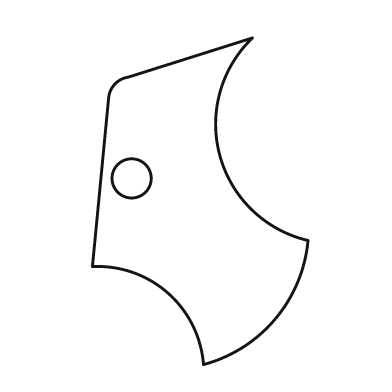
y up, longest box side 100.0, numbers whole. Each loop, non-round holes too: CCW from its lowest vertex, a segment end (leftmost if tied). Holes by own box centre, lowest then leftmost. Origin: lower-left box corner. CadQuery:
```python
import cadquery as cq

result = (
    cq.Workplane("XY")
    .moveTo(34.0, 0.0)
    .threePointArc((56.0, 14.0), (66.0, 38.0))
    .threePointArc((39.0, 64.0), (49.0, 100.0))
    .lineTo(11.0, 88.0)
    .threePointArc((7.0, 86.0), (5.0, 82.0))
    .lineTo(0.0, 30.0)
    .threePointArc((23.0, 22.0), (34.0, 0.0))
    .close()
    .moveTo(12.0, 57.0)
    .circle(6.0)
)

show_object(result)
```